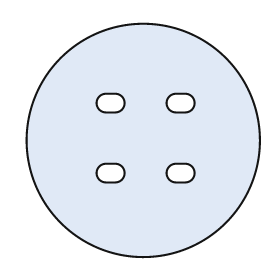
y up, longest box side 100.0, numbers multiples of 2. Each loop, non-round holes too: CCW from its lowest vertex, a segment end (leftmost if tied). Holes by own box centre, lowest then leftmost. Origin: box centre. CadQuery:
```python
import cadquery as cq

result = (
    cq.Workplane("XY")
    .moveTo(0.0, 0.0)
    .circle(50.0)
    .moveTo(-16.0, -18.0)
    .lineTo(-12.0, -18.0)
    .threePointArc((-8.0, -14.0), (-12.0, -10.0))
    .lineTo(-16.0, -10.0)
    .threePointArc((-20.0, -14.0), (-16.0, -18.0))
    .close()
    .moveTo(14.0, -18.0)
    .lineTo(18.0, -18.0)
    .threePointArc((22.0, -14.0), (18.0, -10.0))
    .lineTo(14.0, -10.0)
    .threePointArc((10.0, -14.0), (14.0, -18.0))
    .close()
    .moveTo(-16.0, 12.0)
    .lineTo(-12.0, 12.0)
    .threePointArc((-8.0, 16.0), (-12.0, 20.0))
    .lineTo(-16.0, 20.0)
    .threePointArc((-20.0, 16.0), (-16.0, 12.0))
    .close()
    .moveTo(14.0, 12.0)
    .lineTo(18.0, 12.0)
    .threePointArc((22.0, 16.0), (18.0, 20.0))
    .lineTo(14.0, 20.0)
    .threePointArc((10.0, 16.0), (14.0, 12.0))
    .close()
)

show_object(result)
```